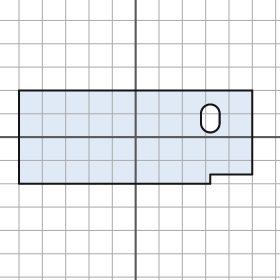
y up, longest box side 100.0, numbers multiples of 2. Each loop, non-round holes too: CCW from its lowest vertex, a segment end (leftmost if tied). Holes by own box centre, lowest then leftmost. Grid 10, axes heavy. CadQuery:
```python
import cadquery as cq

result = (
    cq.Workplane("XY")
    .moveTo(-50.0, -20.0)
    .lineTo(32.0, -20.0)
    .lineTo(32.0, -16.0)
    .lineTo(50.0, -16.0)
    .lineTo(50.0, 20.0)
    .lineTo(-50.0, 20.0)
    .close()
    .moveTo(28.0, 6.0)
    .threePointArc((32.0, 2.0), (36.0, 6.0))
    .lineTo(36.0, 10.0)
    .threePointArc((32.0, 14.0), (28.0, 10.0))
    .close()
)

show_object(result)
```